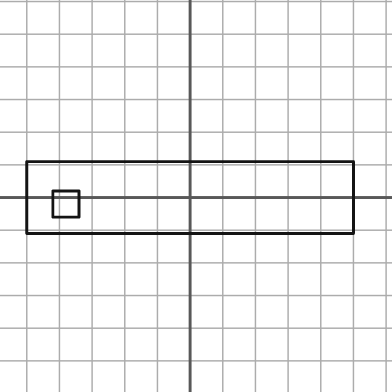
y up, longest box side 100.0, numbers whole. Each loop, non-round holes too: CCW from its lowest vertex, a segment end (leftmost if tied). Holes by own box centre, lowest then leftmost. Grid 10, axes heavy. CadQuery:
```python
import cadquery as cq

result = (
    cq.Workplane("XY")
    .moveTo(-50.0, -11.0)
    .lineTo(50.0, -11.0)
    .lineTo(50.0, 11.0)
    .lineTo(-50.0, 11.0)
    .close()
    .moveTo(-42.0, -6.0)
    .lineTo(-34.0, -6.0)
    .lineTo(-34.0, 2.0)
    .lineTo(-42.0, 2.0)
    .close()
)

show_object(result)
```